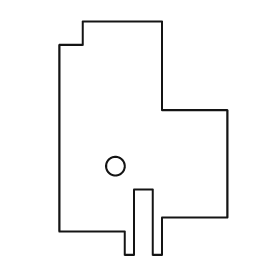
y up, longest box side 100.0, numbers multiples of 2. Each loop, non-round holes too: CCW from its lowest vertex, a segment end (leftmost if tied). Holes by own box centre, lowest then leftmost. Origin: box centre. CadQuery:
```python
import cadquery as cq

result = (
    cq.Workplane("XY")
    .moveTo(-8.0, -50.0)
    .lineTo(-4.0, -50.0)
    .lineTo(-4.0, -22.0)
    .lineTo(4.0, -22.0)
    .lineTo(4.0, -50.0)
    .lineTo(8.0, -50.0)
    .lineTo(8.0, -34.0)
    .lineTo(36.0, -34.0)
    .lineTo(36.0, 12.0)
    .lineTo(8.0, 12.0)
    .lineTo(8.0, 50.0)
    .lineTo(-26.0, 50.0)
    .lineTo(-26.0, 40.0)
    .lineTo(-36.0, 40.0)
    .lineTo(-36.0, -40.0)
    .lineTo(-8.0, -40.0)
    .close()
    .moveTo(-12.0, -12.0)
    .circle(4.0)
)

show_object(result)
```